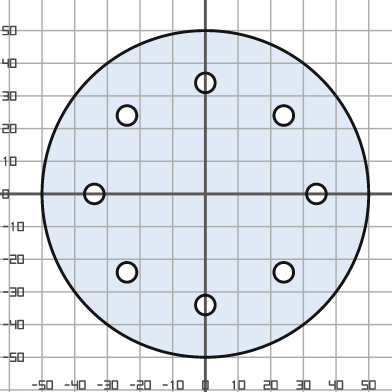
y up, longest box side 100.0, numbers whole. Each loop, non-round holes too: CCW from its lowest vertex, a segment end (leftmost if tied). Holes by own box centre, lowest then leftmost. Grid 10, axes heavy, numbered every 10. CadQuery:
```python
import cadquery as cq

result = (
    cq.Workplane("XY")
    .moveTo(0.0, 0.0)
    .circle(50.0)
    .moveTo(0.0, -34.0)
    .circle(3.0)
    .moveTo(-24.0, -24.0)
    .circle(3.0)
    .moveTo(24.0, -24.0)
    .circle(3.0)
    .moveTo(-34.0, 0.0)
    .circle(3.0)
    .moveTo(34.0, 0.0)
    .circle(3.0)
    .moveTo(-24.0, 24.0)
    .circle(3.0)
    .moveTo(24.0, 24.0)
    .circle(3.0)
    .moveTo(0.0, 34.0)
    .circle(3.0)
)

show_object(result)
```